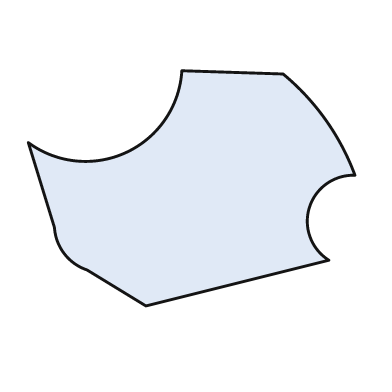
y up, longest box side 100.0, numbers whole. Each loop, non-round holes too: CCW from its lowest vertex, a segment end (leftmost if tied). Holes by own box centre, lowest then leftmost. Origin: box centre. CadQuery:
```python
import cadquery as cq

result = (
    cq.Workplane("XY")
    .moveTo(-14.0, -36.0)
    .lineTo(42.0, -22.0)
    .threePointArc((36.0, -6.0), (50.0, 4.0))
    .threePointArc((41.0, 21.0), (28.0, 35.0))
    .lineTo(-3.0, 36.0)
    .threePointArc((-20.0, 11.0), (-50.0, 14.0))
    .lineTo(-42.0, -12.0)
    .threePointArc((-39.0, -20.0), (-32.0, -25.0))
    .close()
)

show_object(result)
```